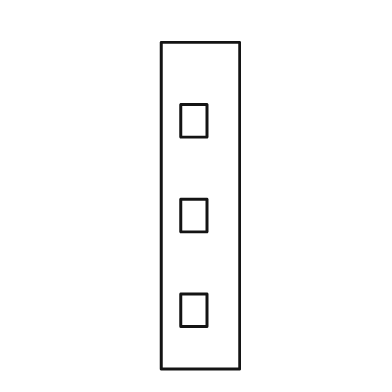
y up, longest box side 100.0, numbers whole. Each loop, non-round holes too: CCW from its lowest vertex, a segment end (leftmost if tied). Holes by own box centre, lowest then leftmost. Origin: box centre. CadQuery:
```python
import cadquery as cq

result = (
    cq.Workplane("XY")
    .moveTo(-12.0, -50.0)
    .lineTo(12.0, -50.0)
    .lineTo(12.0, 50.0)
    .lineTo(-12.0, 50.0)
    .close()
    .moveTo(-6.0, -37.0)
    .lineTo(2.0, -37.0)
    .lineTo(2.0, -27.0)
    .lineTo(-6.0, -27.0)
    .close()
    .moveTo(-6.0, -8.0)
    .lineTo(2.0, -8.0)
    .lineTo(2.0, 2.0)
    .lineTo(-6.0, 2.0)
    .close()
    .moveTo(-6.0, 21.0)
    .lineTo(2.0, 21.0)
    .lineTo(2.0, 31.0)
    .lineTo(-6.0, 31.0)
    .close()
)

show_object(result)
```